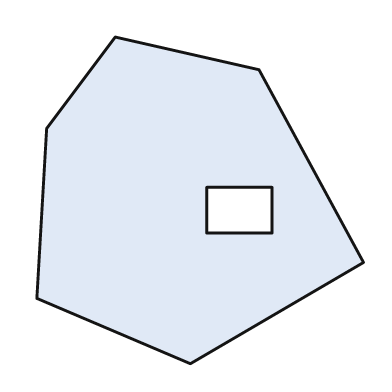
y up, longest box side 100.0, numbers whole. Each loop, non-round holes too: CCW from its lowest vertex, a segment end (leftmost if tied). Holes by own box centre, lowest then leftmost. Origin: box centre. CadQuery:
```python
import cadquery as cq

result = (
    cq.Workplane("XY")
    .moveTo(-3.0, -50.0)
    .lineTo(50.0, -19.0)
    .lineTo(18.0, 40.0)
    .lineTo(-26.0, 50.0)
    .lineTo(-47.0, 22.0)
    .lineTo(-50.0, -30.0)
    .close()
    .moveTo(2.0, -10.0)
    .lineTo(22.0, -10.0)
    .lineTo(22.0, 4.0)
    .lineTo(2.0, 4.0)
    .close()
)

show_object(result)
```